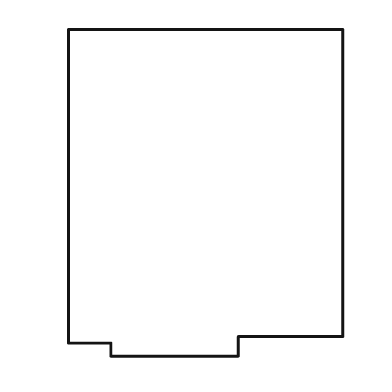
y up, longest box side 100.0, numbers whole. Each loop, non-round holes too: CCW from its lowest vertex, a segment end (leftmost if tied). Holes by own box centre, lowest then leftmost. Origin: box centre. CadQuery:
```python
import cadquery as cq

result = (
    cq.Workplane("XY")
    .moveTo(-29.0, -50.0)
    .lineTo(10.0, -50.0)
    .lineTo(10.0, -44.0)
    .lineTo(42.0, -44.0)
    .lineTo(42.0, 50.0)
    .lineTo(-42.0, 50.0)
    .lineTo(-42.0, -46.0)
    .lineTo(-29.0, -46.0)
    .close()
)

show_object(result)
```